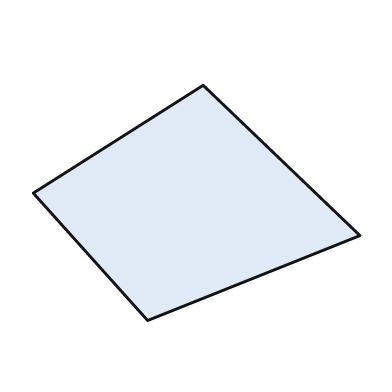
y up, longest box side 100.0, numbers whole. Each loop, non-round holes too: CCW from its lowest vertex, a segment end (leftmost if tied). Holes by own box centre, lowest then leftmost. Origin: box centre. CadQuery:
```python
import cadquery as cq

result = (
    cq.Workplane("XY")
    .moveTo(-15.0, -36.0)
    .lineTo(50.0, -10.0)
    .lineTo(2.0, 36.0)
    .lineTo(-50.0, 3.0)
    .close()
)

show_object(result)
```